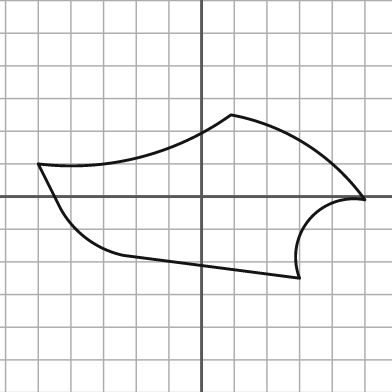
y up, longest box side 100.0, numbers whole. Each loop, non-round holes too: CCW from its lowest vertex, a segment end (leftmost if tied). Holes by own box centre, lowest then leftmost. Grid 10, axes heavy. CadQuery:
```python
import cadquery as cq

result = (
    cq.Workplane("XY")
    .moveTo(30.0, -25.0)
    .threePointArc((33.0, -7.0), (50.0, -1.0))
    .threePointArc((32.0, 16.0), (9.0, 25.0))
    .threePointArc((-19.0, 12.0), (-50.0, 10.0))
    .lineTo(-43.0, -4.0)
    .threePointArc((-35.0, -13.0), (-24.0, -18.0))
    .close()
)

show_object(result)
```